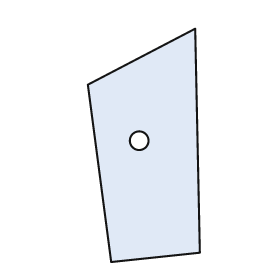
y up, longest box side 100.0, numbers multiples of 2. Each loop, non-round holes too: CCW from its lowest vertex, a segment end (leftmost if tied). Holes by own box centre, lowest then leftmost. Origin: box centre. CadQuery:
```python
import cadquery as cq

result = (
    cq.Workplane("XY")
    .moveTo(-14.0, -50.0)
    .lineTo(24.0, -46.0)
    .lineTo(22.0, 50.0)
    .lineTo(-24.0, 26.0)
    .close()
    .moveTo(-2.0, 2.0)
    .circle(4.0)
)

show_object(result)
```